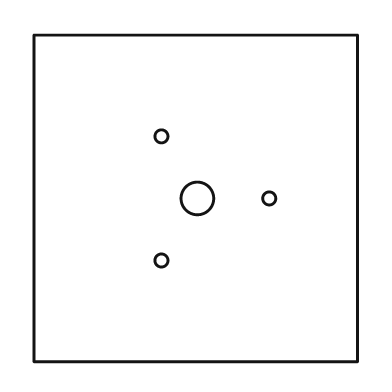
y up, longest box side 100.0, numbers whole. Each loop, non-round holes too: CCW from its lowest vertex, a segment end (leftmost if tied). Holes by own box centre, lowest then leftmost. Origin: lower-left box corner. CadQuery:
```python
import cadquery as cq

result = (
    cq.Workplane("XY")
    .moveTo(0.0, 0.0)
    .lineTo(99.0, 0.0)
    .lineTo(99.0, 100.0)
    .lineTo(0.0, 100.0)
    .close()
    .moveTo(39.0, 31.0)
    .circle(2.0)
    .moveTo(50.0, 50.0)
    .circle(5.0)
    .moveTo(72.0, 50.0)
    .circle(2.0)
    .moveTo(39.0, 69.0)
    .circle(2.0)
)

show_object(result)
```